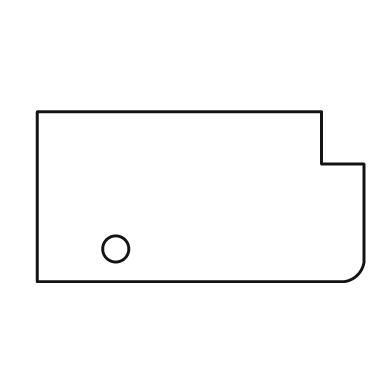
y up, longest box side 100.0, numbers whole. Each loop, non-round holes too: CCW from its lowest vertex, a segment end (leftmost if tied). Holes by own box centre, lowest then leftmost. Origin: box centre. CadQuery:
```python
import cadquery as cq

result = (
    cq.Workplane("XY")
    .moveTo(-50.0, -26.0)
    .lineTo(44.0, -26.0)
    .threePointArc((48.0, -24.0), (50.0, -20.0))
    .lineTo(50.0, 10.0)
    .lineTo(37.0, 10.0)
    .lineTo(37.0, 26.0)
    .lineTo(-50.0, 26.0)
    .close()
    .moveTo(-26.0, -16.0)
    .circle(4.0)
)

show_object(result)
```